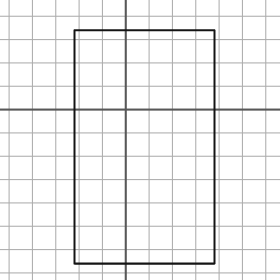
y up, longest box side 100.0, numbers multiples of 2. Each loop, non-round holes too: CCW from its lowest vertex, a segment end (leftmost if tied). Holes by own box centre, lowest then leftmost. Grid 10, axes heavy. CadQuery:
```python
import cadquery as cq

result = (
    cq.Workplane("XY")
    .moveTo(-22.0, -66.0)
    .lineTo(38.0, -66.0)
    .lineTo(38.0, 34.0)
    .lineTo(-22.0, 34.0)
    .close()
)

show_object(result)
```